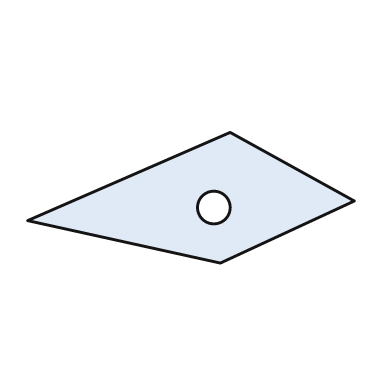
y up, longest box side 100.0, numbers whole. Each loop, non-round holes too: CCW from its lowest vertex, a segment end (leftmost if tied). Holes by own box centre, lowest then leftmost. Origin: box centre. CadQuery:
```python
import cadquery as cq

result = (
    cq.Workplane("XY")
    .moveTo(9.0, -20.0)
    .lineTo(50.0, -1.0)
    .lineTo(12.0, 20.0)
    .lineTo(-50.0, -7.0)
    .close()
    .moveTo(7.0, -3.0)
    .circle(5.0)
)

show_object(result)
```